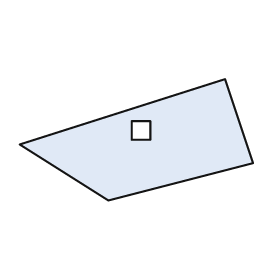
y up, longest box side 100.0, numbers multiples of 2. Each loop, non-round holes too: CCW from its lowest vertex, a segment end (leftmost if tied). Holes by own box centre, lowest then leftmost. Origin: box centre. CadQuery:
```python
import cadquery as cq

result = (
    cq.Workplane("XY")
    .moveTo(-12.0, -26.0)
    .lineTo(50.0, -10.0)
    .lineTo(38.0, 26.0)
    .lineTo(-50.0, -2.0)
    .close()
    .moveTo(-2.0, 0.0)
    .lineTo(6.0, 0.0)
    .lineTo(6.0, 8.0)
    .lineTo(-2.0, 8.0)
    .close()
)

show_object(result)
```